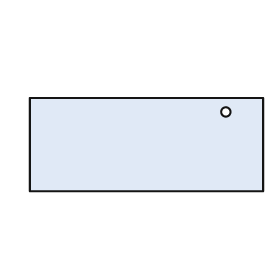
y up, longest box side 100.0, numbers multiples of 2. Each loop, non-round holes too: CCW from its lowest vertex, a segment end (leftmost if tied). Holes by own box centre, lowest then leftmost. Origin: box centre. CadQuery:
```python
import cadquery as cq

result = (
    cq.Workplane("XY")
    .moveTo(-50.0, -20.0)
    .lineTo(50.0, -20.0)
    .lineTo(50.0, 20.0)
    .lineTo(-50.0, 20.0)
    .close()
    .moveTo(34.0, 14.0)
    .circle(2.0)
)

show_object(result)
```